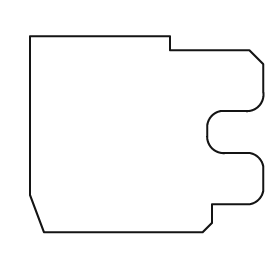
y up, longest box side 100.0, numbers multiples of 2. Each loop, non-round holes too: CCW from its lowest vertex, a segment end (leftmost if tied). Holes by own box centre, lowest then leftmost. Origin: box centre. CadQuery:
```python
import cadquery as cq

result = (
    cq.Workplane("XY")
    .moveTo(-44.0, -42.0)
    .lineTo(24.0, -42.0)
    .lineTo(28.0, -38.0)
    .lineTo(28.0, -30.0)
    .lineTo(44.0, -30.0)
    .threePointArc((48.0, -28.0), (50.0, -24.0))
    .lineTo(50.0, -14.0)
    .threePointArc((48.0, -10.0), (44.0, -8.0))
    .lineTo(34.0, -8.0)
    .threePointArc((28.0, -6.0), (26.0, 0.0))
    .lineTo(26.0, 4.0)
    .threePointArc((28.0, 8.0), (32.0, 10.0))
    .lineTo(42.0, 10.0)
    .threePointArc((48.0, 12.0), (50.0, 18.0))
    .lineTo(50.0, 30.0)
    .lineTo(44.0, 36.0)
    .lineTo(10.0, 36.0)
    .lineTo(10.0, 42.0)
    .lineTo(-50.0, 42.0)
    .lineTo(-50.0, -26.0)
    .close()
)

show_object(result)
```